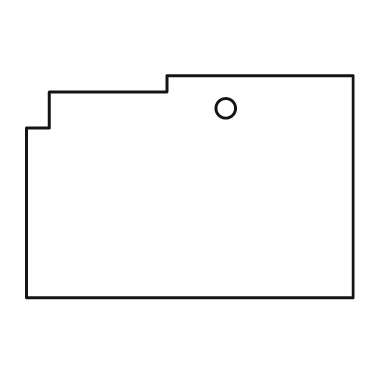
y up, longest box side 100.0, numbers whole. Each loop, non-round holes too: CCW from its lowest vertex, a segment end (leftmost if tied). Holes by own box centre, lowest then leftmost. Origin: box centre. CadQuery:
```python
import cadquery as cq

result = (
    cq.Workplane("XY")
    .moveTo(-50.0, -34.0)
    .lineTo(50.0, -34.0)
    .lineTo(50.0, 34.0)
    .lineTo(-7.0, 34.0)
    .lineTo(-7.0, 29.0)
    .lineTo(-43.0, 29.0)
    .lineTo(-43.0, 18.0)
    .lineTo(-50.0, 18.0)
    .close()
    .moveTo(11.0, 24.0)
    .circle(3.0)
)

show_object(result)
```